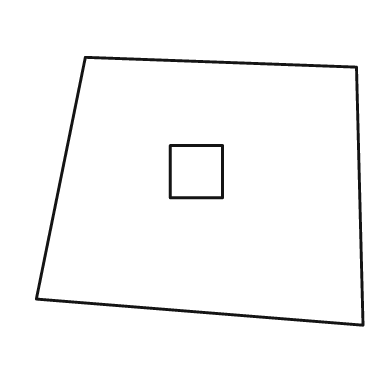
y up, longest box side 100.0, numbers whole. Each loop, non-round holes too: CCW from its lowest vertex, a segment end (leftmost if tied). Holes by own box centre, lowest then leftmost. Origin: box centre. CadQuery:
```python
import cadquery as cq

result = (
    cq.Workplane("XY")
    .moveTo(50.0, -41.0)
    .lineTo(48.0, 38.0)
    .lineTo(-35.0, 41.0)
    .lineTo(-50.0, -33.0)
    .close()
    .moveTo(-9.0, -2.0)
    .lineTo(7.0, -2.0)
    .lineTo(7.0, 14.0)
    .lineTo(-9.0, 14.0)
    .close()
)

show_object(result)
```